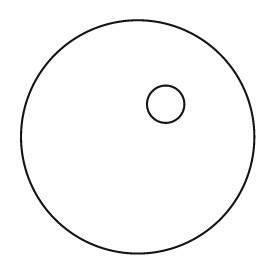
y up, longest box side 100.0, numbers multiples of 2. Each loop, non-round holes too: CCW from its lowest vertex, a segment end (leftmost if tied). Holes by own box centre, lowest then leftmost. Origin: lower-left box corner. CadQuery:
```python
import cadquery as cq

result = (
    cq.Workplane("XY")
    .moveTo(50.0, 50.0)
    .circle(50.0)
    .moveTo(62.0, 64.0)
    .circle(8.0)
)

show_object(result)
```